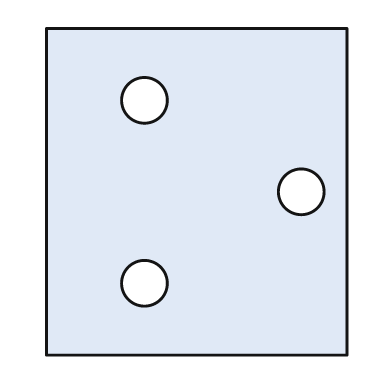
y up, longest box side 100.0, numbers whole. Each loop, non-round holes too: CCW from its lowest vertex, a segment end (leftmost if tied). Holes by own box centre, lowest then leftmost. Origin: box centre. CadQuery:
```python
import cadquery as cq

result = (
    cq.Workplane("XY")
    .moveTo(-46.0, -50.0)
    .lineTo(46.0, -50.0)
    .lineTo(46.0, 50.0)
    .lineTo(-46.0, 50.0)
    .close()
    .moveTo(-16.0, -28.0)
    .circle(7.0)
    .moveTo(32.0, 0.0)
    .circle(7.0)
    .moveTo(-16.0, 28.0)
    .circle(7.0)
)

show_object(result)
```